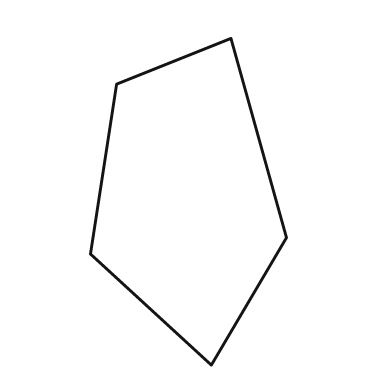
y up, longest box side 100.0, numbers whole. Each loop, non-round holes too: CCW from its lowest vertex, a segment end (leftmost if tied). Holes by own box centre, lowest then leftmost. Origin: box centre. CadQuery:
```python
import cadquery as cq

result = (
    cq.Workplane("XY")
    .moveTo(7.0, -50.0)
    .lineTo(30.0, -11.0)
    .lineTo(13.0, 50.0)
    .lineTo(-22.0, 36.0)
    .lineTo(-30.0, -16.0)
    .close()
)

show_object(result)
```